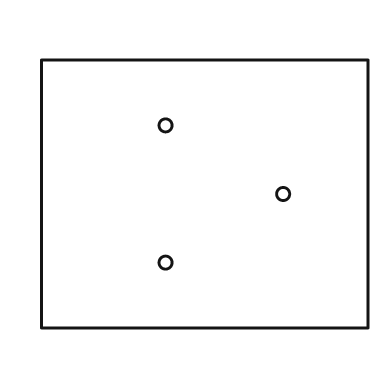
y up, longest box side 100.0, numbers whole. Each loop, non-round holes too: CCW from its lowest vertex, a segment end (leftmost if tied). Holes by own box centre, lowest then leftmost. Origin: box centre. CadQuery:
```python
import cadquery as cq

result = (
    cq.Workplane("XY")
    .moveTo(-50.0, -41.0)
    .lineTo(50.0, -41.0)
    .lineTo(50.0, 41.0)
    .lineTo(-50.0, 41.0)
    .close()
    .moveTo(-12.0, -21.0)
    .circle(2.0)
    .moveTo(24.0, 0.0)
    .circle(2.0)
    .moveTo(-12.0, 21.0)
    .circle(2.0)
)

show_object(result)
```